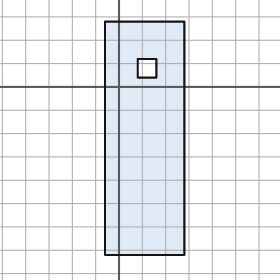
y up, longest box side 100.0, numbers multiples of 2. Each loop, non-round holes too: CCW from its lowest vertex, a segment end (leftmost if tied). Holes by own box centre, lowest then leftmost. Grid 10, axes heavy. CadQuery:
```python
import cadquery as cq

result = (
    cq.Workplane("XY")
    .moveTo(-6.0, -72.0)
    .lineTo(28.0, -72.0)
    .lineTo(28.0, 28.0)
    .lineTo(-6.0, 28.0)
    .close()
    .moveTo(8.0, 4.0)
    .lineTo(16.0, 4.0)
    .lineTo(16.0, 12.0)
    .lineTo(8.0, 12.0)
    .close()
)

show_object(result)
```